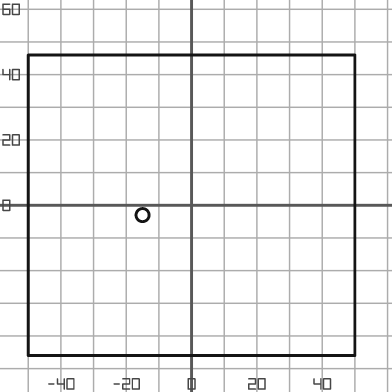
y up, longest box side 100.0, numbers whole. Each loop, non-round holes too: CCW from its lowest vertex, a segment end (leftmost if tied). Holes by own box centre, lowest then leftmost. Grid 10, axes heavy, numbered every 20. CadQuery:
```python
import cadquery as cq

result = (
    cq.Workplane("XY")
    .moveTo(-50.0, -46.0)
    .lineTo(50.0, -46.0)
    .lineTo(50.0, 46.0)
    .lineTo(-50.0, 46.0)
    .close()
    .moveTo(-15.0, -3.0)
    .circle(2.0)
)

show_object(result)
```